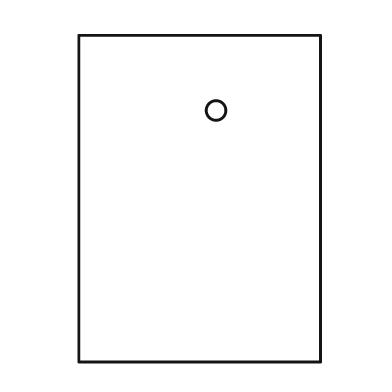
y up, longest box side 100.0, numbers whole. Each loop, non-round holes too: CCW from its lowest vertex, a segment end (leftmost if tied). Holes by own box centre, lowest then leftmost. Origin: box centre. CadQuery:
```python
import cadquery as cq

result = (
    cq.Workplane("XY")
    .moveTo(-37.0, -50.0)
    .lineTo(37.0, -50.0)
    .lineTo(37.0, 50.0)
    .lineTo(-37.0, 50.0)
    .close()
    .moveTo(5.0, 27.0)
    .circle(3.0)
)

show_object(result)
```